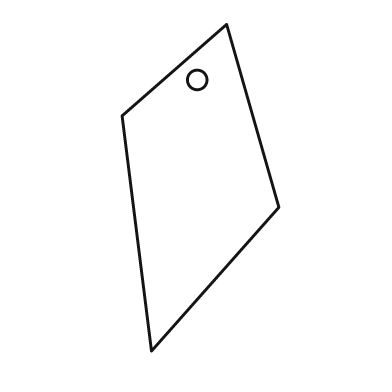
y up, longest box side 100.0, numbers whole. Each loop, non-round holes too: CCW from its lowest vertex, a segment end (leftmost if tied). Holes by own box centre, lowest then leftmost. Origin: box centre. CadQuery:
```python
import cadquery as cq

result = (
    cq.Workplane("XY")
    .moveTo(-15.0, -50.0)
    .lineTo(24.0, -6.0)
    .lineTo(8.0, 50.0)
    .lineTo(-24.0, 22.0)
    .close()
    .moveTo(-1.0, 33.0)
    .circle(3.0)
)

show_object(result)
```